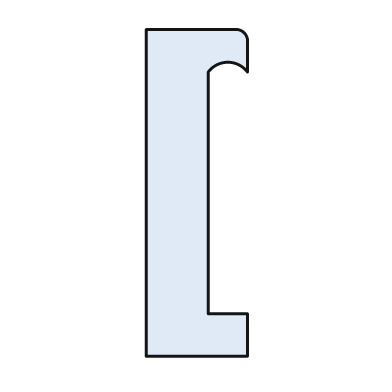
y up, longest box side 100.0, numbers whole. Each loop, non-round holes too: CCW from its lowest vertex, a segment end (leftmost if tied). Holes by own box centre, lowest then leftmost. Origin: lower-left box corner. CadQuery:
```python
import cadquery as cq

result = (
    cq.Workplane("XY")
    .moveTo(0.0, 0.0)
    .lineTo(31.0, 0.0)
    .lineTo(31.0, 13.0)
    .lineTo(19.0, 13.0)
    .lineTo(19.0, 87.0)
    .threePointArc((25.0, 90.0), (31.0, 87.0))
    .lineTo(31.0, 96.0)
    .threePointArc((30.0, 99.0), (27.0, 100.0))
    .lineTo(0.0, 100.0)
    .close()
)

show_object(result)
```